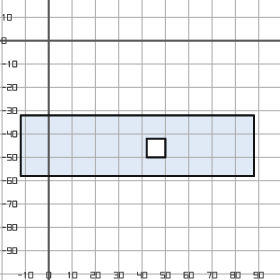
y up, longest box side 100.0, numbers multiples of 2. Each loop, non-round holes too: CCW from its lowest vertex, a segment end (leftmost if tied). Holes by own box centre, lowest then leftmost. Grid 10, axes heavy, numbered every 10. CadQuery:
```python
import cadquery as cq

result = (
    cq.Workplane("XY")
    .moveTo(-12.0, -58.0)
    .lineTo(88.0, -58.0)
    .lineTo(88.0, -32.0)
    .lineTo(-12.0, -32.0)
    .close()
    .moveTo(42.0, -50.0)
    .lineTo(50.0, -50.0)
    .lineTo(50.0, -42.0)
    .lineTo(42.0, -42.0)
    .close()
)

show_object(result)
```